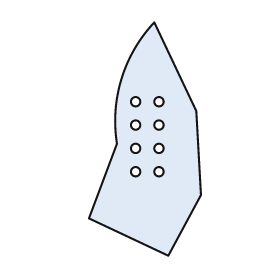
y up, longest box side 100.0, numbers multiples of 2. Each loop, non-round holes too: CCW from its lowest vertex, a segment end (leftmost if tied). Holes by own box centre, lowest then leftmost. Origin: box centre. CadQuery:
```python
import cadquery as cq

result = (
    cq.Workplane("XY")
    .moveTo(10.0, -50.0)
    .lineTo(24.0, -24.0)
    .lineTo(22.0, 12.0)
    .lineTo(4.0, 50.0)
    .threePointArc((-10.0, 26.0), (-12.0, -2.0))
    .lineTo(-24.0, -34.0)
    .close()
    .moveTo(-4.0, -14.0)
    .circle(2.0)
    .moveTo(6.0, -14.0)
    .circle(2.0)
    .moveTo(-4.0, -4.0)
    .circle(2.0)
    .moveTo(6.0, -4.0)
    .circle(2.0)
    .moveTo(-4.0, 6.0)
    .circle(2.0)
    .moveTo(6.0, 6.0)
    .circle(2.0)
    .moveTo(-4.0, 16.0)
    .circle(2.0)
    .moveTo(6.0, 16.0)
    .circle(2.0)
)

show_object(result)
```